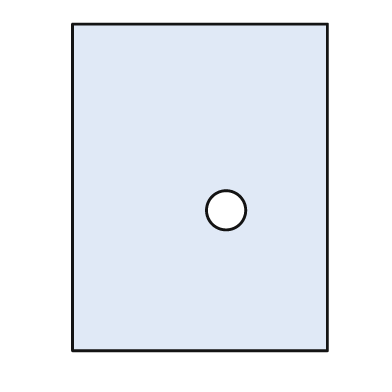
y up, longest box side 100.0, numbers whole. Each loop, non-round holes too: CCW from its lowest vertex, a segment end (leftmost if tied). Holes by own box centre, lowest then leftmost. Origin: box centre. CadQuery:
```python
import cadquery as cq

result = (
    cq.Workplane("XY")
    .moveTo(-39.0, -50.0)
    .lineTo(39.0, -50.0)
    .lineTo(39.0, 50.0)
    .lineTo(-39.0, 50.0)
    .close()
    .moveTo(8.0, -7.0)
    .circle(6.0)
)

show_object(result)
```